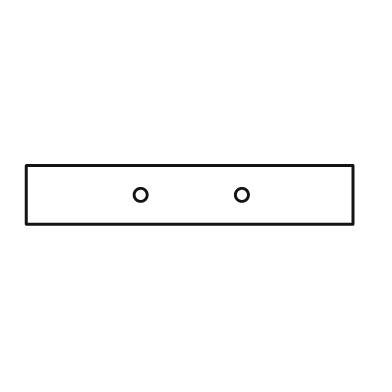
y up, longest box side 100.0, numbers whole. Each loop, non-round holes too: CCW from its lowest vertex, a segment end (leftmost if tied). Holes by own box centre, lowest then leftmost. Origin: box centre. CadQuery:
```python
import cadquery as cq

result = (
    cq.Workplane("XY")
    .moveTo(-50.0, -9.0)
    .lineTo(50.0, -9.0)
    .lineTo(50.0, 9.0)
    .lineTo(-50.0, 9.0)
    .close()
    .moveTo(-15.0, 0.0)
    .circle(2.0)
    .moveTo(16.0, 0.0)
    .circle(2.0)
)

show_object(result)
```